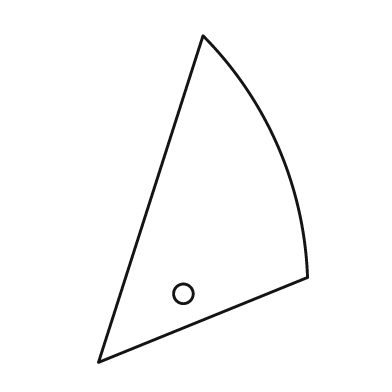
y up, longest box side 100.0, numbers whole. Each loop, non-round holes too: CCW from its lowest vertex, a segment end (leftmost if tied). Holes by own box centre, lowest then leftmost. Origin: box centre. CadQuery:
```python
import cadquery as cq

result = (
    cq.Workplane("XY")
    .moveTo(-32.0, -50.0)
    .lineTo(32.0, -24.0)
    .threePointArc((23.0, 16.0), (0.0, 50.0))
    .close()
    .moveTo(-6.0, -29.0)
    .circle(3.0)
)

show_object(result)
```